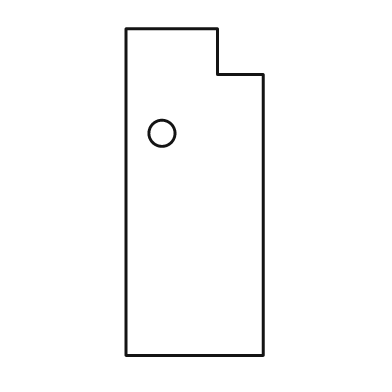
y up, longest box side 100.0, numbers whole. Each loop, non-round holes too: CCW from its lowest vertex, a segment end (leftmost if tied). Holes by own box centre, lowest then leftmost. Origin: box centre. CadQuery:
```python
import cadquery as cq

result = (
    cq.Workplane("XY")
    .moveTo(-21.0, -50.0)
    .lineTo(21.0, -50.0)
    .lineTo(21.0, 36.0)
    .lineTo(7.0, 36.0)
    .lineTo(7.0, 50.0)
    .lineTo(-21.0, 50.0)
    .close()
    .moveTo(-10.0, 18.0)
    .circle(4.0)
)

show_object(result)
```